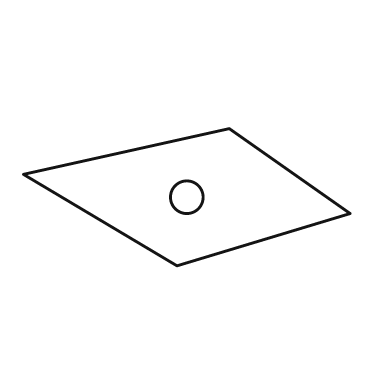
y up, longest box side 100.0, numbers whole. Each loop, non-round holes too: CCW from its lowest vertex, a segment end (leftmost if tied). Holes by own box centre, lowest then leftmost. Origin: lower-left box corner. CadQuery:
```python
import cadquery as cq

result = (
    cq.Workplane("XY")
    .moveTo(47.0, 0.0)
    .lineTo(100.0, 16.0)
    .lineTo(63.0, 42.0)
    .lineTo(0.0, 28.0)
    .close()
    .moveTo(50.0, 21.0)
    .circle(5.0)
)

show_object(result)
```